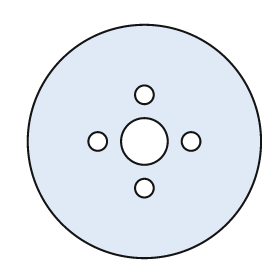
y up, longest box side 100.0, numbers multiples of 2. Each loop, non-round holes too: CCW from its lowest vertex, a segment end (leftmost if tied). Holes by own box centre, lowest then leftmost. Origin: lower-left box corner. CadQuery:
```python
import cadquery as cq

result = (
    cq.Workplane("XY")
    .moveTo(50.0, 50.0)
    .circle(50.0)
    .moveTo(50.0, 30.0)
    .circle(4.0)
    .moveTo(30.0, 50.0)
    .circle(4.0)
    .moveTo(50.0, 50.0)
    .circle(10.0)
    .moveTo(70.0, 50.0)
    .circle(4.0)
    .moveTo(50.0, 70.0)
    .circle(4.0)
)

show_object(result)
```